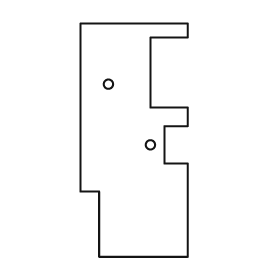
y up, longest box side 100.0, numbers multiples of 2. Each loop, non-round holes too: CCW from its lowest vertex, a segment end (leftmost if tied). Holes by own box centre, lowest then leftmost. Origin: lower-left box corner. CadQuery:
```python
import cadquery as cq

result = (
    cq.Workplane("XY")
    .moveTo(8.0, 0.0)
    .lineTo(46.0, 0.0)
    .lineTo(46.0, 40.0)
    .lineTo(36.0, 40.0)
    .lineTo(36.0, 56.0)
    .lineTo(46.0, 56.0)
    .lineTo(46.0, 64.0)
    .lineTo(30.0, 64.0)
    .lineTo(30.0, 94.0)
    .lineTo(46.0, 94.0)
    .lineTo(46.0, 100.0)
    .lineTo(0.0, 100.0)
    .lineTo(0.0, 28.0)
    .lineTo(8.0, 28.0)
    .close()
    .moveTo(30.0, 48.0)
    .circle(2.0)
    .moveTo(12.0, 74.0)
    .circle(2.0)
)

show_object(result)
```